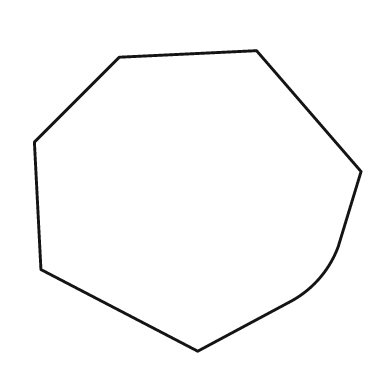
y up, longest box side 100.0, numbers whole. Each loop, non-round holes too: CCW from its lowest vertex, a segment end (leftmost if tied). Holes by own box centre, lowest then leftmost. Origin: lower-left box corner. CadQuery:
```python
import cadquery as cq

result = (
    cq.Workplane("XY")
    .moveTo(50.0, 0.0)
    .lineTo(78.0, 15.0)
    .threePointArc((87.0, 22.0), (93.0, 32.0))
    .lineTo(100.0, 55.0)
    .lineTo(68.0, 92.0)
    .lineTo(26.0, 90.0)
    .lineTo(0.0, 64.0)
    .lineTo(2.0, 25.0)
    .close()
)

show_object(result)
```